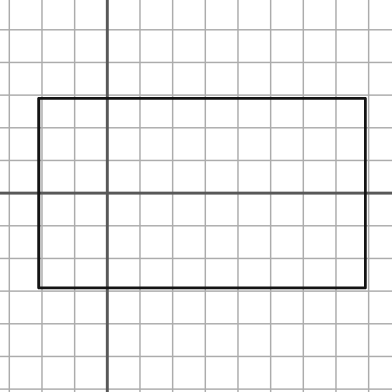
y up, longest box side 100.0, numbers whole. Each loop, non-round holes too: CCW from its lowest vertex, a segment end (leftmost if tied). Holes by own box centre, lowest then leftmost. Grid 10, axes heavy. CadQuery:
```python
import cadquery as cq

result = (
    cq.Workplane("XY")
    .moveTo(-21.0, -29.0)
    .lineTo(79.0, -29.0)
    .lineTo(79.0, 29.0)
    .lineTo(-21.0, 29.0)
    .close()
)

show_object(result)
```